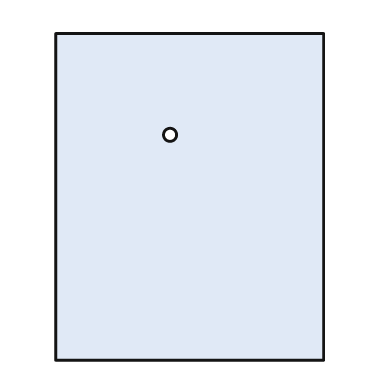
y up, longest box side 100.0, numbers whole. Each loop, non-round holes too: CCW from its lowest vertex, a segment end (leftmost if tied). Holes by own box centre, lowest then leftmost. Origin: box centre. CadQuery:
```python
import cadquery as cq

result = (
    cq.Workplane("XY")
    .moveTo(-41.0, -50.0)
    .lineTo(41.0, -50.0)
    .lineTo(41.0, 50.0)
    .lineTo(-41.0, 50.0)
    .close()
    .moveTo(-6.0, 19.0)
    .circle(2.0)
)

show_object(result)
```